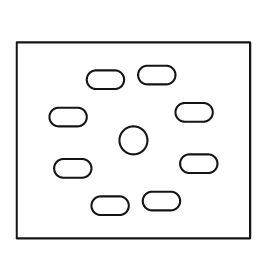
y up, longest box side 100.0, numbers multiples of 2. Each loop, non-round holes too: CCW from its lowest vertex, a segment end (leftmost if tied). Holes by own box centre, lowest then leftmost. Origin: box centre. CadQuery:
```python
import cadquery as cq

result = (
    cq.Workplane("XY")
    .moveTo(-50.0, -42.0)
    .lineTo(50.0, -42.0)
    .lineTo(50.0, 42.0)
    .lineTo(-50.0, 42.0)
    .close()
    .moveTo(-14.0, -32.0)
    .lineTo(-6.0, -32.0)
    .threePointArc((-2.0, -28.0), (-6.0, -24.0))
    .lineTo(-14.0, -24.0)
    .threePointArc((-18.0, -28.0), (-14.0, -32.0))
    .close()
    .moveTo(8.0, -30.0)
    .lineTo(16.0, -30.0)
    .threePointArc((20.0, -26.0), (16.0, -22.0))
    .lineTo(8.0, -22.0)
    .threePointArc((4.0, -26.0), (8.0, -30.0))
    .close()
    .moveTo(-30.0, -16.0)
    .lineTo(-22.0, -16.0)
    .threePointArc((-18.0, -12.0), (-22.0, -8.0))
    .lineTo(-30.0, -8.0)
    .threePointArc((-34.0, -12.0), (-30.0, -16.0))
    .close()
    .moveTo(24.0, -14.0)
    .lineTo(32.0, -14.0)
    .threePointArc((36.0, -10.0), (32.0, -6.0))
    .lineTo(24.0, -6.0)
    .threePointArc((20.0, -10.0), (24.0, -14.0))
    .close()
    .moveTo(0.0, 0.0)
    .circle(6.0)
    .moveTo(-32.0, 6.0)
    .lineTo(-24.0, 6.0)
    .threePointArc((-20.0, 10.0), (-24.0, 14.0))
    .lineTo(-32.0, 14.0)
    .threePointArc((-36.0, 10.0), (-32.0, 6.0))
    .close()
    .moveTo(22.0, 8.0)
    .lineTo(30.0, 8.0)
    .threePointArc((34.0, 12.0), (30.0, 16.0))
    .lineTo(22.0, 16.0)
    .threePointArc((18.0, 12.0), (22.0, 8.0))
    .close()
    .moveTo(-16.0, 22.0)
    .lineTo(-8.0, 22.0)
    .threePointArc((-4.0, 26.0), (-8.0, 30.0))
    .lineTo(-16.0, 30.0)
    .threePointArc((-20.0, 26.0), (-16.0, 22.0))
    .close()
    .moveTo(6.0, 24.0)
    .lineTo(14.0, 24.0)
    .threePointArc((18.0, 28.0), (14.0, 32.0))
    .lineTo(6.0, 32.0)
    .threePointArc((2.0, 28.0), (6.0, 24.0))
    .close()
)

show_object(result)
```